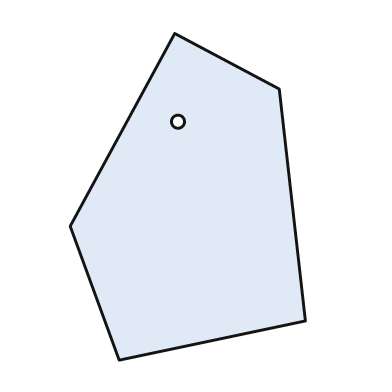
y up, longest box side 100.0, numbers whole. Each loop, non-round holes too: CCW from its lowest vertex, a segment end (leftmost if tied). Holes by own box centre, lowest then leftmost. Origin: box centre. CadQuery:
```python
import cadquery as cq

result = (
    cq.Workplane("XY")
    .moveTo(-21.0, -50.0)
    .lineTo(36.0, -38.0)
    .lineTo(28.0, 33.0)
    .lineTo(-4.0, 50.0)
    .lineTo(-36.0, -9.0)
    .close()
    .moveTo(-3.0, 23.0)
    .circle(2.0)
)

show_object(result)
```